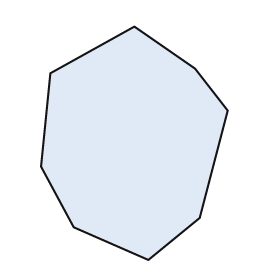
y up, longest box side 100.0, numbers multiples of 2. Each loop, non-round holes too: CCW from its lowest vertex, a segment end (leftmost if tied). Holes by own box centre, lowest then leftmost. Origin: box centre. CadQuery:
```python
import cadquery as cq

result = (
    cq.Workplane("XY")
    .moveTo(6.0, -50.0)
    .lineTo(28.0, -32.0)
    .lineTo(40.0, 14.0)
    .lineTo(26.0, 32.0)
    .lineTo(0.0, 50.0)
    .lineTo(-36.0, 30.0)
    .lineTo(-40.0, -10.0)
    .lineTo(-26.0, -36.0)
    .close()
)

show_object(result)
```